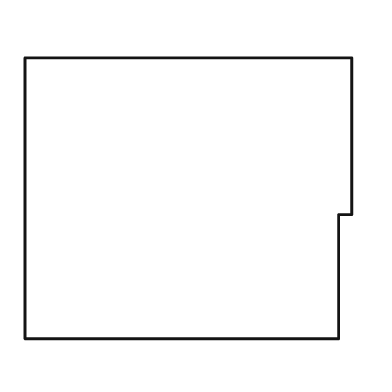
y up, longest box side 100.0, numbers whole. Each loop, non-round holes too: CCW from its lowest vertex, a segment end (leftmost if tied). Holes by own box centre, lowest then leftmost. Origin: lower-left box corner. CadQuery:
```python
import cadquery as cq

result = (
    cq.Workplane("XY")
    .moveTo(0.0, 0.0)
    .lineTo(96.0, 0.0)
    .lineTo(96.0, 38.0)
    .lineTo(100.0, 38.0)
    .lineTo(100.0, 86.0)
    .lineTo(0.0, 86.0)
    .close()
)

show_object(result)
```